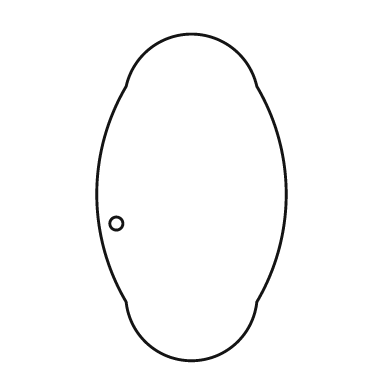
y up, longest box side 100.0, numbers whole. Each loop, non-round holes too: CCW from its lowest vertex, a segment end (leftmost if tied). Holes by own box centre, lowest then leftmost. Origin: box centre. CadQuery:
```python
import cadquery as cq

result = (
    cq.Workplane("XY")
    .moveTo(-20.0, -32.0)
    .threePointArc((0.0, -50.0), (20.0, -32.0))
    .threePointArc((29.0, 1.0), (20.0, 34.0))
    .threePointArc((0.0, 50.0), (-20.0, 34.0))
    .threePointArc((-29.0, 1.0), (-20.0, -32.0))
    .close()
    .moveTo(-23.0, -8.0)
    .circle(2.0)
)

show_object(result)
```